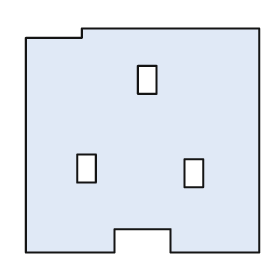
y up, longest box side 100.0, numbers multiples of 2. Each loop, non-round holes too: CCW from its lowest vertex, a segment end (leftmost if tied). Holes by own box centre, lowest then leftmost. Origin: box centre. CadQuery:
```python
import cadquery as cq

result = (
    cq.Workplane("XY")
    .moveTo(-50.0, -48.0)
    .lineTo(-12.0, -48.0)
    .lineTo(-12.0, -38.0)
    .lineTo(12.0, -38.0)
    .lineTo(12.0, -48.0)
    .lineTo(50.0, -48.0)
    .lineTo(50.0, 48.0)
    .lineTo(-26.0, 48.0)
    .lineTo(-26.0, 44.0)
    .lineTo(-50.0, 44.0)
    .close()
    .moveTo(18.0, -20.0)
    .lineTo(26.0, -20.0)
    .lineTo(26.0, -8.0)
    .lineTo(18.0, -8.0)
    .close()
    .moveTo(-28.0, -18.0)
    .lineTo(-20.0, -18.0)
    .lineTo(-20.0, -6.0)
    .lineTo(-28.0, -6.0)
    .close()
    .moveTo(-2.0, 20.0)
    .lineTo(6.0, 20.0)
    .lineTo(6.0, 32.0)
    .lineTo(-2.0, 32.0)
    .close()
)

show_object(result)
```